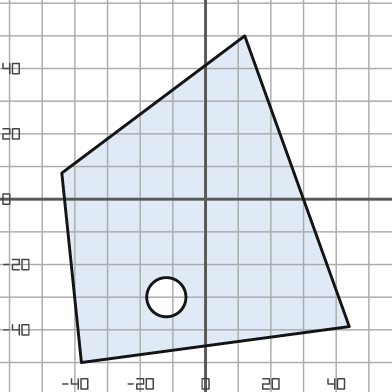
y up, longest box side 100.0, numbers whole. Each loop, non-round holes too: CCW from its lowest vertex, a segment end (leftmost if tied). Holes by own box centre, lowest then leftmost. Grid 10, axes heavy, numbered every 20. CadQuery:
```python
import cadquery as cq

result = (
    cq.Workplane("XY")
    .moveTo(-38.0, -50.0)
    .lineTo(44.0, -39.0)
    .lineTo(12.0, 50.0)
    .lineTo(-44.0, 8.0)
    .close()
    .moveTo(-12.0, -30.0)
    .circle(6.0)
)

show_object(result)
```